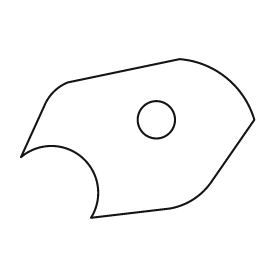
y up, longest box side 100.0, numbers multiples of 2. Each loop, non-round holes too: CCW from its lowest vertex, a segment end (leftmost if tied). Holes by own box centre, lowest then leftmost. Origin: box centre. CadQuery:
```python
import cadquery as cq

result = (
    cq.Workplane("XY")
    .moveTo(-20.0, -34.0)
    .lineTo(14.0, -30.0)
    .threePointArc((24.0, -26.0), (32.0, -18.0))
    .lineTo(50.0, 8.0)
    .threePointArc((38.0, 26.0), (18.0, 34.0))
    .lineTo(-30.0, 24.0)
    .threePointArc((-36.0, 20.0), (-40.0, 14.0))
    .lineTo(-50.0, -8.0)
    .threePointArc((-24.0, -8.0), (-20.0, -34.0))
    .close()
    .moveTo(8.0, 8.0)
    .circle(8.0)
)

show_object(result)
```